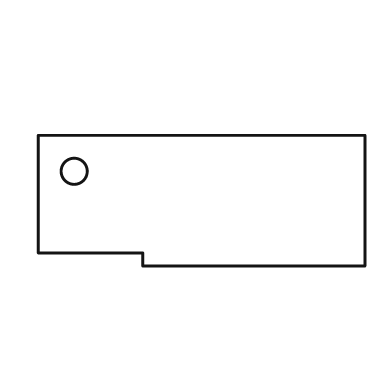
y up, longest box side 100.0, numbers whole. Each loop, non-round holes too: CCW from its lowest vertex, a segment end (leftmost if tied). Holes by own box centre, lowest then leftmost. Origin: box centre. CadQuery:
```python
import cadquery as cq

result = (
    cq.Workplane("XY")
    .moveTo(-18.0, -20.0)
    .lineTo(50.0, -20.0)
    .lineTo(50.0, 20.0)
    .lineTo(-50.0, 20.0)
    .lineTo(-50.0, -16.0)
    .lineTo(-18.0, -16.0)
    .close()
    .moveTo(-39.0, 9.0)
    .circle(4.0)
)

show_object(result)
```